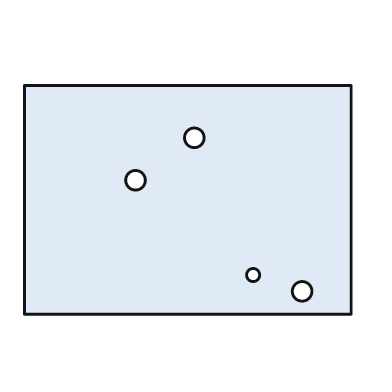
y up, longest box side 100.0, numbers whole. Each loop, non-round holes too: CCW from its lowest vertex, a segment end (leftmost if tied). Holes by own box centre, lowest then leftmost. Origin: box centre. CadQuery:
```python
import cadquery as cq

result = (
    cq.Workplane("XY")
    .moveTo(-50.0, -35.0)
    .lineTo(50.0, -35.0)
    .lineTo(50.0, 35.0)
    .lineTo(-50.0, 35.0)
    .close()
    .moveTo(35.0, -28.0)
    .circle(3.0)
    .moveTo(20.0, -23.0)
    .circle(2.0)
    .moveTo(-16.0, 6.0)
    .circle(3.0)
    .moveTo(2.0, 19.0)
    .circle(3.0)
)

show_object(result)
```